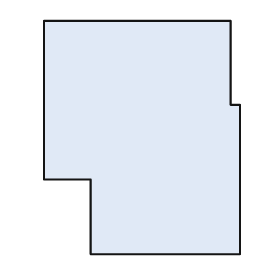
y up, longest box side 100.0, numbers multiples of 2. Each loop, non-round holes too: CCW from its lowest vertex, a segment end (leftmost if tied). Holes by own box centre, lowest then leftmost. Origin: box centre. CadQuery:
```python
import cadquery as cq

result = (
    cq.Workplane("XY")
    .moveTo(-22.0, -50.0)
    .lineTo(42.0, -50.0)
    .lineTo(42.0, 14.0)
    .lineTo(38.0, 14.0)
    .lineTo(38.0, 50.0)
    .lineTo(-42.0, 50.0)
    .lineTo(-42.0, -18.0)
    .lineTo(-22.0, -18.0)
    .close()
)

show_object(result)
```